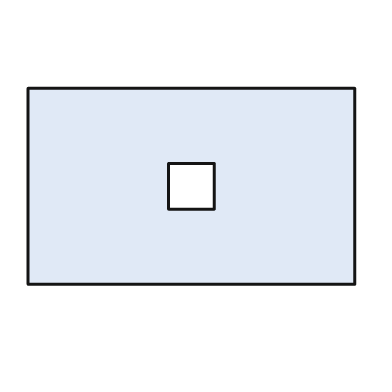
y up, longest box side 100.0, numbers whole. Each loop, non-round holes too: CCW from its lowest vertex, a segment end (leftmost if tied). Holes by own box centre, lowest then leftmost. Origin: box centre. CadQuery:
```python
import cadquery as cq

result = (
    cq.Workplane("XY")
    .moveTo(-50.0, -30.0)
    .lineTo(50.0, -30.0)
    .lineTo(50.0, 30.0)
    .lineTo(-50.0, 30.0)
    .close()
    .moveTo(-7.0, -7.0)
    .lineTo(7.0, -7.0)
    .lineTo(7.0, 7.0)
    .lineTo(-7.0, 7.0)
    .close()
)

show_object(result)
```